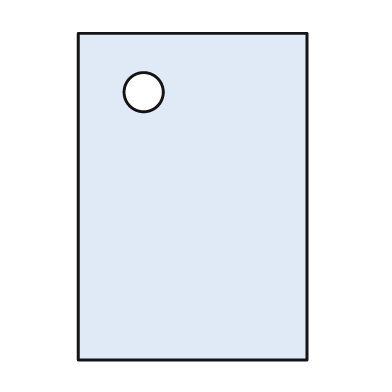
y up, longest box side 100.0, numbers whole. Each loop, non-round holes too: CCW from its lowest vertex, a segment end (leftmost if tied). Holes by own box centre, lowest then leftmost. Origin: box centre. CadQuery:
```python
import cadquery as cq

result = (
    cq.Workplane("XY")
    .moveTo(-35.0, -50.0)
    .lineTo(35.0, -50.0)
    .lineTo(35.0, 50.0)
    .lineTo(-35.0, 50.0)
    .close()
    .moveTo(-15.0, 32.0)
    .circle(6.0)
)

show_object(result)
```